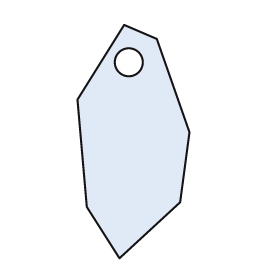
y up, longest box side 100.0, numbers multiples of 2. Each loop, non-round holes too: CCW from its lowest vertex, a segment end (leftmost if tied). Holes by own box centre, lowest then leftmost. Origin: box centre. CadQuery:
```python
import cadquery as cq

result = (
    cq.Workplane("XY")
    .moveTo(-6.0, -50.0)
    .lineTo(20.0, -26.0)
    .lineTo(24.0, 4.0)
    .lineTo(10.0, 44.0)
    .lineTo(-4.0, 50.0)
    .lineTo(-24.0, 18.0)
    .lineTo(-20.0, -28.0)
    .close()
    .moveTo(-2.0, 34.0)
    .circle(6.0)
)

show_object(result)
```